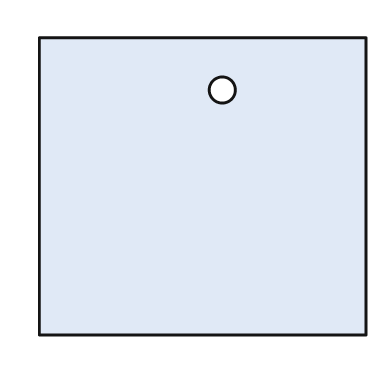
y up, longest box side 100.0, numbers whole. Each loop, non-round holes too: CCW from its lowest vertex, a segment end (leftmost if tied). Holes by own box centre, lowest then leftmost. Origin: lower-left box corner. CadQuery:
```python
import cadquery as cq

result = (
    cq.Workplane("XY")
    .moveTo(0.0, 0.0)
    .lineTo(100.0, 0.0)
    .lineTo(100.0, 91.0)
    .lineTo(0.0, 91.0)
    .close()
    .moveTo(56.0, 75.0)
    .circle(4.0)
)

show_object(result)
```